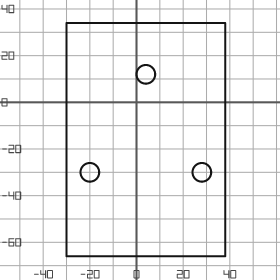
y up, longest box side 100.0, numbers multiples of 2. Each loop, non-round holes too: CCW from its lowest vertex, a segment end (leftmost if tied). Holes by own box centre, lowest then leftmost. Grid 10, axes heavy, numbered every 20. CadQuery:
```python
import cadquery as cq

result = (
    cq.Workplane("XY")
    .moveTo(-30.0, -66.0)
    .lineTo(38.0, -66.0)
    .lineTo(38.0, 34.0)
    .lineTo(-30.0, 34.0)
    .close()
    .moveTo(-20.0, -30.0)
    .circle(4.0)
    .moveTo(28.0, -30.0)
    .circle(4.0)
    .moveTo(4.0, 12.0)
    .circle(4.0)
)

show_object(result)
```